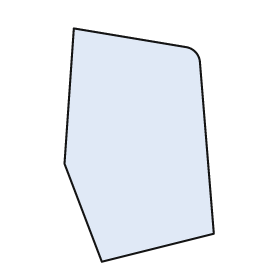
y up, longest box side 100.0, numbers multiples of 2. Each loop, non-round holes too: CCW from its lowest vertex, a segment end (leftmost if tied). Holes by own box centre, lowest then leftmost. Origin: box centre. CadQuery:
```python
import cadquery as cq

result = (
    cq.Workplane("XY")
    .moveTo(-16.0, -50.0)
    .lineTo(32.0, -38.0)
    .lineTo(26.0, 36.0)
    .threePointArc((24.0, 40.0), (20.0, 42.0))
    .lineTo(-28.0, 50.0)
    .lineTo(-32.0, -8.0)
    .close()
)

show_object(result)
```